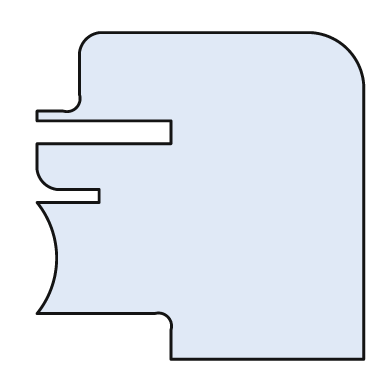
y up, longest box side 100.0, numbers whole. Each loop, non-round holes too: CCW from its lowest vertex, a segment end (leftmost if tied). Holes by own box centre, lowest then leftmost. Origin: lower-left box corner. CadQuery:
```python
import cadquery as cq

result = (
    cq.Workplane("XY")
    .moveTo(41.0, 0.0)
    .lineTo(100.0, 0.0)
    .lineTo(100.0, 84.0)
    .threePointArc((95.0, 95.0), (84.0, 100.0))
    .lineTo(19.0, 100.0)
    .threePointArc((15.0, 98.0), (13.0, 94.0))
    .lineTo(13.0, 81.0)
    .threePointArc((12.0, 77.0), (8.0, 76.0))
    .lineTo(0.0, 76.0)
    .lineTo(0.0, 73.0)
    .lineTo(41.0, 73.0)
    .lineTo(41.0, 66.0)
    .lineTo(0.0, 66.0)
    .lineTo(0.0, 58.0)
    .threePointArc((2.0, 54.0), (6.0, 52.0))
    .lineTo(19.0, 52.0)
    .lineTo(19.0, 48.0)
    .lineTo(0.0, 48.0)
    .threePointArc((6.0, 31.0), (0.0, 14.0))
    .lineTo(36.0, 14.0)
    .threePointArc((40.0, 13.0), (41.0, 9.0))
    .close()
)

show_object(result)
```